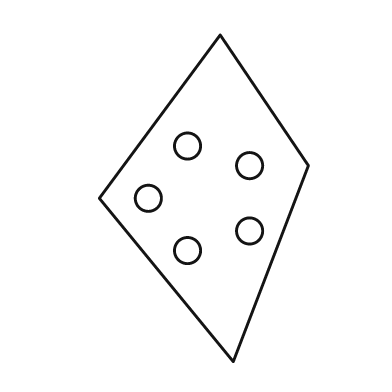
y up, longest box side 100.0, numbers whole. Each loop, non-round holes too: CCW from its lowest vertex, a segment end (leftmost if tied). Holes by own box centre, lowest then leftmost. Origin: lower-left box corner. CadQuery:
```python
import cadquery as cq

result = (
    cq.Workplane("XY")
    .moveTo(41.0, 0.0)
    .lineTo(64.0, 60.0)
    .lineTo(37.0, 100.0)
    .lineTo(0.0, 50.0)
    .close()
    .moveTo(27.0, 34.0)
    .circle(4.0)
    .moveTo(46.0, 40.0)
    .circle(4.0)
    .moveTo(15.0, 50.0)
    .circle(4.0)
    .moveTo(46.0, 60.0)
    .circle(4.0)
    .moveTo(27.0, 66.0)
    .circle(4.0)
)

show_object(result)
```